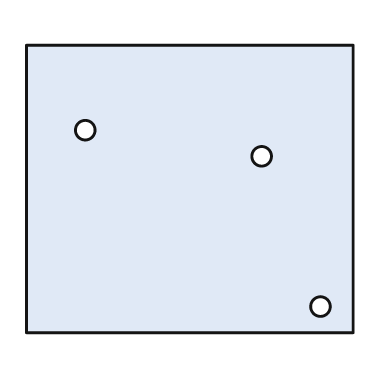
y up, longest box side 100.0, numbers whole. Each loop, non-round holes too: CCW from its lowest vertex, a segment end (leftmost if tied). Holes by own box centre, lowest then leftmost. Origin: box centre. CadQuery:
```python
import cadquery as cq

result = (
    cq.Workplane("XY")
    .moveTo(-50.0, -44.0)
    .lineTo(50.0, -44.0)
    .lineTo(50.0, 44.0)
    .lineTo(-50.0, 44.0)
    .close()
    .moveTo(40.0, -36.0)
    .circle(3.0)
    .moveTo(22.0, 10.0)
    .circle(3.0)
    .moveTo(-32.0, 18.0)
    .circle(3.0)
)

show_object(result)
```